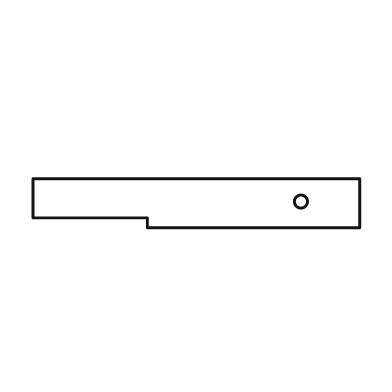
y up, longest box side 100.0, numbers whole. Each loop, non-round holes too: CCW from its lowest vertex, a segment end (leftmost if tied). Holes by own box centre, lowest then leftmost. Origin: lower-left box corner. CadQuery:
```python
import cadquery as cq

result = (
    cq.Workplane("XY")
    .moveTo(35.0, 0.0)
    .lineTo(100.0, 0.0)
    .lineTo(100.0, 15.0)
    .lineTo(0.0, 15.0)
    .lineTo(0.0, 3.0)
    .lineTo(35.0, 3.0)
    .close()
    .moveTo(82.0, 8.0)
    .circle(2.0)
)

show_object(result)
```